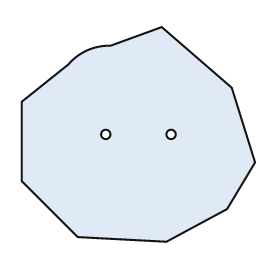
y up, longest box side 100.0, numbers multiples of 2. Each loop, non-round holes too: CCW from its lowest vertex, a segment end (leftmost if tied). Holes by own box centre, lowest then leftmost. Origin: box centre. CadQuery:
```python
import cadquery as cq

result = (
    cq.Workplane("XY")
    .moveTo(12.0, -46.0)
    .lineTo(38.0, -32.0)
    .lineTo(50.0, -12.0)
    .lineTo(40.0, 20.0)
    .lineTo(10.0, 46.0)
    .lineTo(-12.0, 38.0)
    .threePointArc((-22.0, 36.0), (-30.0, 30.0))
    .lineTo(-50.0, 14.0)
    .lineTo(-50.0, -20.0)
    .lineTo(-26.0, -44.0)
    .close()
    .moveTo(-14.0, 0.0)
    .circle(2.0)
    .moveTo(14.0, 0.0)
    .circle(2.0)
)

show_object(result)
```